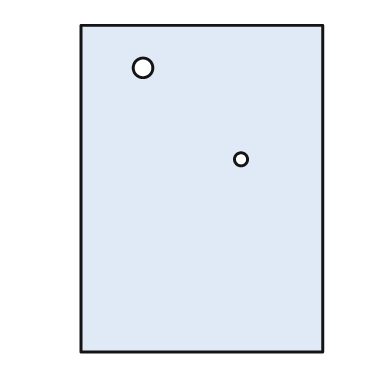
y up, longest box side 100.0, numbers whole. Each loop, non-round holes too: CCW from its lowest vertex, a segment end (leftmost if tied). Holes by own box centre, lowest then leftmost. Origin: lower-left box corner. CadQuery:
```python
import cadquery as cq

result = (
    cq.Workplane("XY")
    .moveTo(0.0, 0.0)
    .lineTo(74.0, 0.0)
    .lineTo(74.0, 100.0)
    .lineTo(0.0, 100.0)
    .close()
    .moveTo(49.0, 59.0)
    .circle(2.0)
    .moveTo(19.0, 87.0)
    .circle(3.0)
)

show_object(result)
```